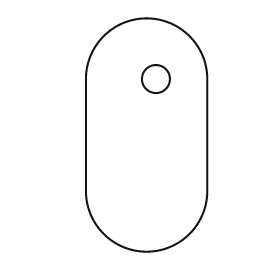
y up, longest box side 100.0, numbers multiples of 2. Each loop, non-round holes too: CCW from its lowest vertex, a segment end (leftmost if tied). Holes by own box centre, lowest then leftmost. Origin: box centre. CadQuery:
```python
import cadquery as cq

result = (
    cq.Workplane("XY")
    .moveTo(-26.0, -24.0)
    .threePointArc((0.0, -50.0), (26.0, -24.0))
    .lineTo(26.0, 24.0)
    .threePointArc((0.0, 50.0), (-26.0, 24.0))
    .close()
    .moveTo(4.0, 24.0)
    .circle(6.0)
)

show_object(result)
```